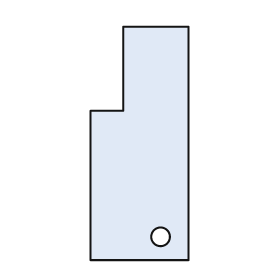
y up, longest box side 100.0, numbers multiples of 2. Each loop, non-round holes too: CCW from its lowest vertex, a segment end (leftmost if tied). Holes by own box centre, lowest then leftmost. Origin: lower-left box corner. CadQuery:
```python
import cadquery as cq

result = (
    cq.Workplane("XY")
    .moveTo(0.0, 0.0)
    .lineTo(42.0, 0.0)
    .lineTo(42.0, 100.0)
    .lineTo(14.0, 100.0)
    .lineTo(14.0, 64.0)
    .lineTo(0.0, 64.0)
    .close()
    .moveTo(30.0, 10.0)
    .circle(4.0)
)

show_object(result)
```